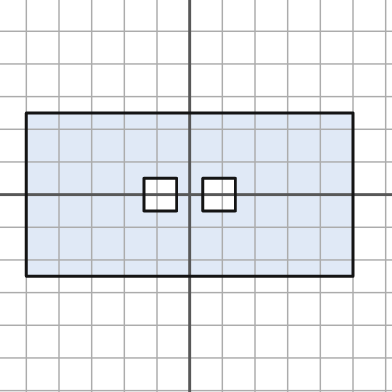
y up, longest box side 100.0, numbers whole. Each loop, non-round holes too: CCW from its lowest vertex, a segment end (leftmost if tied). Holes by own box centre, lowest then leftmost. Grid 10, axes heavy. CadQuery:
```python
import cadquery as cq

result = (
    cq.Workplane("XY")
    .moveTo(-50.0, -25.0)
    .lineTo(50.0, -25.0)
    .lineTo(50.0, 25.0)
    .lineTo(-50.0, 25.0)
    .close()
    .moveTo(-14.0, -5.0)
    .lineTo(-4.0, -5.0)
    .lineTo(-4.0, 5.0)
    .lineTo(-14.0, 5.0)
    .close()
    .moveTo(4.0, -5.0)
    .lineTo(14.0, -5.0)
    .lineTo(14.0, 5.0)
    .lineTo(4.0, 5.0)
    .close()
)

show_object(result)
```